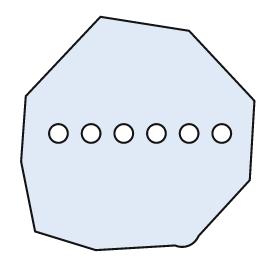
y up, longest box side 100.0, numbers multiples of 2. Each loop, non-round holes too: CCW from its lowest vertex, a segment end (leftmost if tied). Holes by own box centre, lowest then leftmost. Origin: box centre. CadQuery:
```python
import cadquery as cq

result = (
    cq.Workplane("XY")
    .moveTo(-18.0, -50.0)
    .lineTo(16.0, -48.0)
    .threePointArc((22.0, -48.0), (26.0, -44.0))
    .lineTo(48.0, -20.0)
    .lineTo(50.0, 14.0)
    .lineTo(22.0, 44.0)
    .lineTo(-16.0, 50.0)
    .lineTo(-48.0, 16.0)
    .lineTo(-50.0, -12.0)
    .lineTo(-44.0, -42.0)
    .close()
    .moveTo(-34.0, 0.0)
    .circle(4.0)
    .moveTo(-20.0, 0.0)
    .circle(4.0)
    .moveTo(-6.0, 0.0)
    .circle(4.0)
    .moveTo(8.0, 0.0)
    .circle(4.0)
    .moveTo(22.0, 0.0)
    .circle(4.0)
    .moveTo(36.0, 0.0)
    .circle(4.0)
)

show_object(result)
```